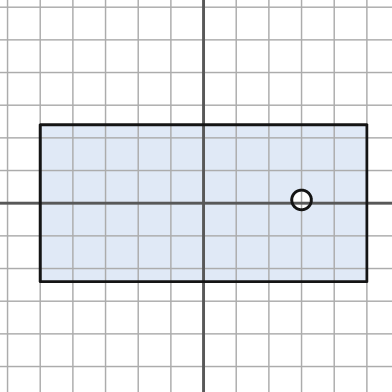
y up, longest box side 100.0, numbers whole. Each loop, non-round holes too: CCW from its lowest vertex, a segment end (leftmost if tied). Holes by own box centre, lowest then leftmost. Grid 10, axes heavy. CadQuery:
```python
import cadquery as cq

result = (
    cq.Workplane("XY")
    .moveTo(-50.0, -24.0)
    .lineTo(50.0, -24.0)
    .lineTo(50.0, 24.0)
    .lineTo(-50.0, 24.0)
    .close()
    .moveTo(30.0, 1.0)
    .circle(3.0)
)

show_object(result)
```